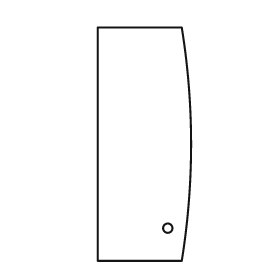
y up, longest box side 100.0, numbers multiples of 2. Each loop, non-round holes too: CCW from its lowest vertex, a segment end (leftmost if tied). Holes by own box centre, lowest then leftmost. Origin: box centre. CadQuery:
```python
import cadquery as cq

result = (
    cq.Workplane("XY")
    .moveTo(-20.0, -50.0)
    .lineTo(16.0, -50.0)
    .threePointArc((20.0, 0.0), (16.0, 50.0))
    .lineTo(-20.0, 50.0)
    .close()
    .moveTo(10.0, -36.0)
    .circle(2.0)
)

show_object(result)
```